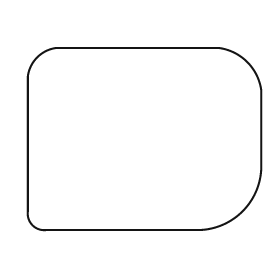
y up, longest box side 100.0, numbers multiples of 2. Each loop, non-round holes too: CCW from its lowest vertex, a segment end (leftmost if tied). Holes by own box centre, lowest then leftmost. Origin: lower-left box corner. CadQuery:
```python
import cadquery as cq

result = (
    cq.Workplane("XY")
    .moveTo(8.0, 0.0)
    .lineTo(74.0, 0.0)
    .threePointArc((92.0, 8.0), (100.0, 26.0))
    .lineTo(100.0, 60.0)
    .threePointArc((94.0, 72.0), (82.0, 78.0))
    .lineTo(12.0, 78.0)
    .threePointArc((4.0, 74.0), (0.0, 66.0))
    .lineTo(0.0, 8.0)
    .threePointArc((2.0, 2.0), (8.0, 0.0))
    .close()
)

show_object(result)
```